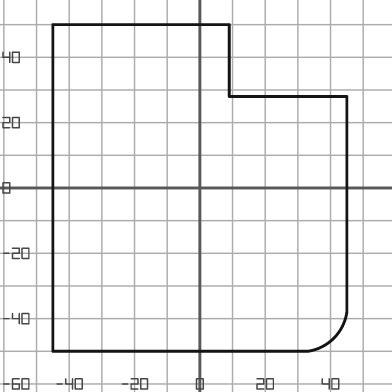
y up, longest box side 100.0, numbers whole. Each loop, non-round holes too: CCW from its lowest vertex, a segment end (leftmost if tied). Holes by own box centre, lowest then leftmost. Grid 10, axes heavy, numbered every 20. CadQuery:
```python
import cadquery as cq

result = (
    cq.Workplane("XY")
    .moveTo(-45.0, -50.0)
    .lineTo(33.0, -50.0)
    .threePointArc((41.0, -46.0), (45.0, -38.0))
    .lineTo(45.0, 28.0)
    .lineTo(9.0, 28.0)
    .lineTo(9.0, 50.0)
    .lineTo(-45.0, 50.0)
    .close()
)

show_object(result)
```